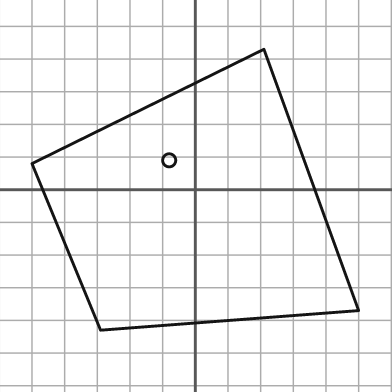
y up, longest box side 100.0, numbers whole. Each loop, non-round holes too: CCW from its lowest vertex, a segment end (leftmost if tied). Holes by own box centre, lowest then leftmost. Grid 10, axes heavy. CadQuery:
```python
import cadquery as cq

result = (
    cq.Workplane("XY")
    .moveTo(-29.0, -43.0)
    .lineTo(50.0, -37.0)
    .lineTo(21.0, 43.0)
    .lineTo(-50.0, 8.0)
    .close()
    .moveTo(-8.0, 9.0)
    .circle(2.0)
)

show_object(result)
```